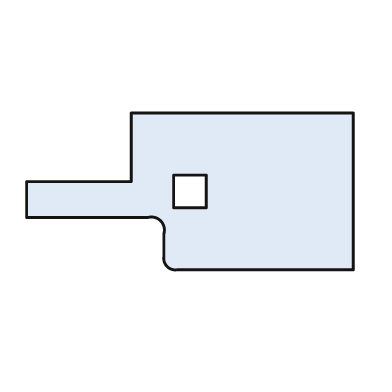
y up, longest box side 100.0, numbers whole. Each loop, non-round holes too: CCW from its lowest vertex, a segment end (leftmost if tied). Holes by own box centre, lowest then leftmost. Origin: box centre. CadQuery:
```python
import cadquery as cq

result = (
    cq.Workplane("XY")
    .moveTo(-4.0, -24.0)
    .lineTo(50.0, -24.0)
    .lineTo(50.0, 24.0)
    .lineTo(-18.0, 24.0)
    .lineTo(-18.0, 3.0)
    .lineTo(-50.0, 3.0)
    .lineTo(-50.0, -8.0)
    .lineTo(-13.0, -8.0)
    .threePointArc((-9.0, -9.0), (-8.0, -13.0))
    .lineTo(-8.0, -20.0)
    .threePointArc((-7.0, -23.0), (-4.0, -24.0))
    .close()
    .moveTo(-5.0, -5.0)
    .lineTo(5.0, -5.0)
    .lineTo(5.0, 5.0)
    .lineTo(-5.0, 5.0)
    .close()
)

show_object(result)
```